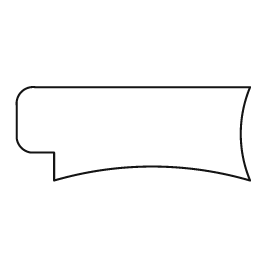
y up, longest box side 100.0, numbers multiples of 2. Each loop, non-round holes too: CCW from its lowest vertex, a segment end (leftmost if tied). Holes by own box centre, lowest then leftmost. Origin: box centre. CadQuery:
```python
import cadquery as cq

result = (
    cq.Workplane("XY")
    .moveTo(-34.0, -20.0)
    .threePointArc((8.0, -14.0), (50.0, -20.0))
    .threePointArc((46.0, 0.0), (50.0, 20.0))
    .lineTo(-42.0, 20.0)
    .threePointArc((-48.0, 18.0), (-50.0, 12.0))
    .lineTo(-50.0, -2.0)
    .threePointArc((-48.0, -6.0), (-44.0, -8.0))
    .lineTo(-34.0, -8.0)
    .close()
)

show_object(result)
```